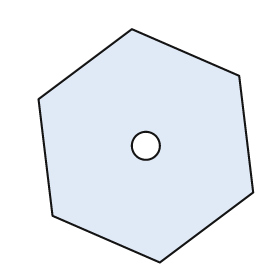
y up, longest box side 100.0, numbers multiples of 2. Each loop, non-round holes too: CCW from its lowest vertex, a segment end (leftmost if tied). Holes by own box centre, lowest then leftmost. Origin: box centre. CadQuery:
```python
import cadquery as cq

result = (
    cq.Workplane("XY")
    .moveTo(6.0, -50.0)
    .lineTo(46.0, -20.0)
    .lineTo(40.0, 30.0)
    .lineTo(-6.0, 50.0)
    .lineTo(-46.0, 20.0)
    .lineTo(-40.0, -30.0)
    .close()
    .moveTo(0.0, 0.0)
    .circle(6.0)
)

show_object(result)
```